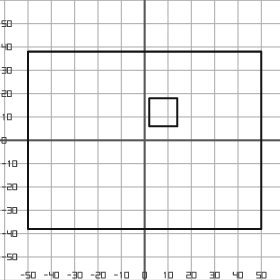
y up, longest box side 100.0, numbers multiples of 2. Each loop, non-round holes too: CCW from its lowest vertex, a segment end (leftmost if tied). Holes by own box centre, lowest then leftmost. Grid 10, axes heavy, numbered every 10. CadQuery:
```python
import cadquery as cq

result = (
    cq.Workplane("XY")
    .moveTo(-50.0, -38.0)
    .lineTo(50.0, -38.0)
    .lineTo(50.0, 38.0)
    .lineTo(-50.0, 38.0)
    .close()
    .moveTo(2.0, 6.0)
    .lineTo(14.0, 6.0)
    .lineTo(14.0, 18.0)
    .lineTo(2.0, 18.0)
    .close()
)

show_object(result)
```